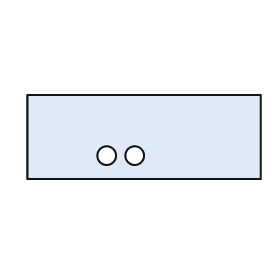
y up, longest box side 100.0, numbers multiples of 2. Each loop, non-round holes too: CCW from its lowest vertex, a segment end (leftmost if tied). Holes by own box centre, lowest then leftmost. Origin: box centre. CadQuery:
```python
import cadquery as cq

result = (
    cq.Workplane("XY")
    .moveTo(-50.0, -18.0)
    .lineTo(50.0, -18.0)
    .lineTo(50.0, 18.0)
    .lineTo(-50.0, 18.0)
    .close()
    .moveTo(-16.0, -8.0)
    .circle(4.0)
    .moveTo(-4.0, -8.0)
    .circle(4.0)
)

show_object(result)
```